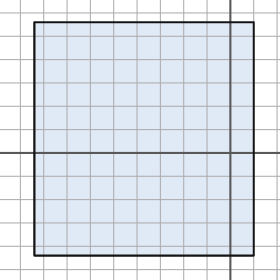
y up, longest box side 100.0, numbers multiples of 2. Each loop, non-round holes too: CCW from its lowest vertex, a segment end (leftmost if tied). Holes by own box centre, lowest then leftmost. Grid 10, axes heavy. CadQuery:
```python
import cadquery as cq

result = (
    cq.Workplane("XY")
    .moveTo(-84.0, -44.0)
    .lineTo(10.0, -44.0)
    .lineTo(10.0, 56.0)
    .lineTo(-84.0, 56.0)
    .close()
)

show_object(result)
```